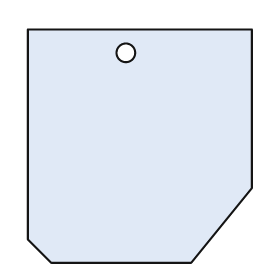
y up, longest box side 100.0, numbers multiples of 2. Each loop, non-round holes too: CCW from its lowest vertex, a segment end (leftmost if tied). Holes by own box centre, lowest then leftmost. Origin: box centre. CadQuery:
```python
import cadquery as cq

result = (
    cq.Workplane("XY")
    .moveTo(-38.0, -50.0)
    .lineTo(22.0, -50.0)
    .lineTo(48.0, -18.0)
    .lineTo(48.0, 50.0)
    .lineTo(-48.0, 50.0)
    .lineTo(-48.0, -40.0)
    .close()
    .moveTo(-6.0, 40.0)
    .circle(4.0)
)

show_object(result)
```